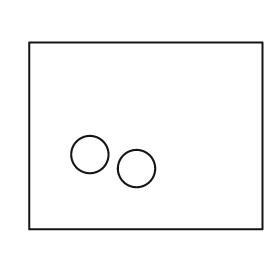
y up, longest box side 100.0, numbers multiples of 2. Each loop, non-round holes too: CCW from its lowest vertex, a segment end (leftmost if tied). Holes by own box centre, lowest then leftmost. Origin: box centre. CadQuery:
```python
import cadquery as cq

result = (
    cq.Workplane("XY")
    .moveTo(-50.0, -40.0)
    .lineTo(50.0, -40.0)
    .lineTo(50.0, 40.0)
    .lineTo(-50.0, 40.0)
    .close()
    .moveTo(-4.0, -14.0)
    .circle(8.0)
    .moveTo(-24.0, -8.0)
    .circle(8.0)
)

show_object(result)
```